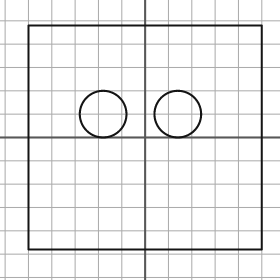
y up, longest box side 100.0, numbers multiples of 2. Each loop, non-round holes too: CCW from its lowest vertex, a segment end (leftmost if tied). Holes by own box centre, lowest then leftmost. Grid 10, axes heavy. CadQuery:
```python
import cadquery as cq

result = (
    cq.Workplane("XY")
    .moveTo(-50.0, -48.0)
    .lineTo(50.0, -48.0)
    .lineTo(50.0, 48.0)
    .lineTo(-50.0, 48.0)
    .close()
    .moveTo(-18.0, 10.0)
    .circle(10.0)
    .moveTo(14.0, 10.0)
    .circle(10.0)
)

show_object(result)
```